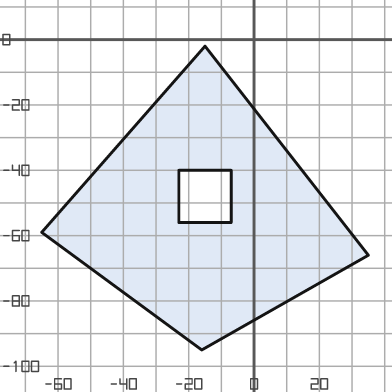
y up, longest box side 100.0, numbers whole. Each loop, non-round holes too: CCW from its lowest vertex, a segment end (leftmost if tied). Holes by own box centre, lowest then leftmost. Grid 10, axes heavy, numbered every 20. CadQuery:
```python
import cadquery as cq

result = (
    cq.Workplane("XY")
    .moveTo(-16.0, -95.0)
    .lineTo(35.0, -66.0)
    .lineTo(-15.0, -2.0)
    .lineTo(-65.0, -59.0)
    .close()
    .moveTo(-23.0, -56.0)
    .lineTo(-7.0, -56.0)
    .lineTo(-7.0, -40.0)
    .lineTo(-23.0, -40.0)
    .close()
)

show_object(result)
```